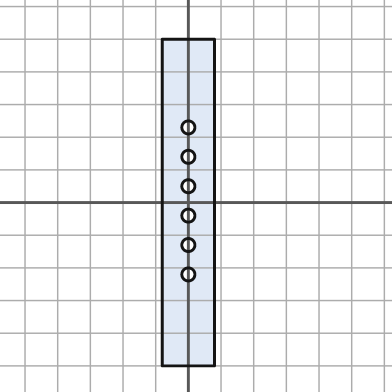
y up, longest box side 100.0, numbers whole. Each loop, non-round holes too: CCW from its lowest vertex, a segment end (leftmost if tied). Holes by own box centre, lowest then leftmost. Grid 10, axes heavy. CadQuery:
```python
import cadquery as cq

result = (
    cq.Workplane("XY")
    .moveTo(-8.0, -50.0)
    .lineTo(8.0, -50.0)
    .lineTo(8.0, 50.0)
    .lineTo(-8.0, 50.0)
    .close()
    .moveTo(0.0, -22.0)
    .circle(2.0)
    .moveTo(0.0, -13.0)
    .circle(2.0)
    .moveTo(0.0, -4.0)
    .circle(2.0)
    .moveTo(0.0, 5.0)
    .circle(2.0)
    .moveTo(0.0, 14.0)
    .circle(2.0)
    .moveTo(0.0, 23.0)
    .circle(2.0)
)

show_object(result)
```